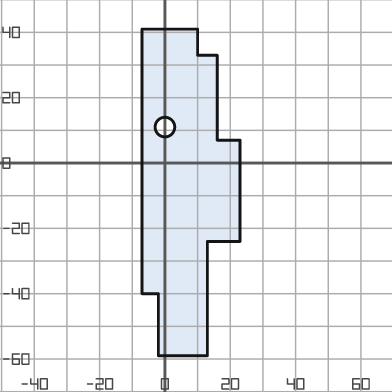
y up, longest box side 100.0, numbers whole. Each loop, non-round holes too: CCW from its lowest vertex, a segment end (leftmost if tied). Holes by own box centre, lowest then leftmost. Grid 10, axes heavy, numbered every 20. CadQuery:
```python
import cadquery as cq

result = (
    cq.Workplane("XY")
    .moveTo(-2.0, -59.0)
    .lineTo(13.0, -59.0)
    .lineTo(13.0, -24.0)
    .lineTo(23.0, -24.0)
    .lineTo(23.0, 7.0)
    .lineTo(16.0, 7.0)
    .lineTo(16.0, 33.0)
    .lineTo(10.0, 33.0)
    .lineTo(10.0, 41.0)
    .lineTo(-7.0, 41.0)
    .lineTo(-7.0, -40.0)
    .lineTo(-2.0, -40.0)
    .close()
    .moveTo(0.0, 11.0)
    .circle(3.0)
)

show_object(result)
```